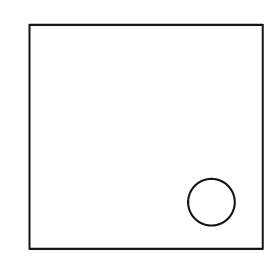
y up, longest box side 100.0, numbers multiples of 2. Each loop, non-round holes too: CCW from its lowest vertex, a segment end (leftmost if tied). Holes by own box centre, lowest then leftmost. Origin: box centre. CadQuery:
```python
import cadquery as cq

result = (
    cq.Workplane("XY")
    .moveTo(-50.0, -48.0)
    .lineTo(50.0, -48.0)
    .lineTo(50.0, 48.0)
    .lineTo(-50.0, 48.0)
    .close()
    .moveTo(28.0, -28.0)
    .circle(10.0)
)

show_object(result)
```